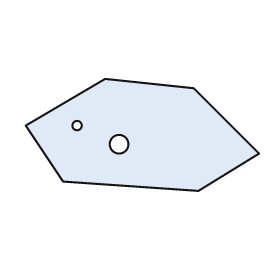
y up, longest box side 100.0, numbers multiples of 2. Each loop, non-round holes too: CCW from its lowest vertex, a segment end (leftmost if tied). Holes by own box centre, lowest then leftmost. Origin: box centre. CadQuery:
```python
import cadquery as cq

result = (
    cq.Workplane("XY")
    .moveTo(24.0, -24.0)
    .lineTo(50.0, -8.0)
    .lineTo(22.0, 20.0)
    .lineTo(-16.0, 24.0)
    .lineTo(-50.0, 4.0)
    .lineTo(-34.0, -20.0)
    .close()
    .moveTo(-10.0, -4.0)
    .circle(4.0)
    .moveTo(-28.0, 4.0)
    .circle(2.0)
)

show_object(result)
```